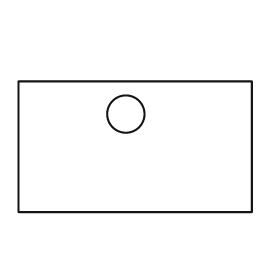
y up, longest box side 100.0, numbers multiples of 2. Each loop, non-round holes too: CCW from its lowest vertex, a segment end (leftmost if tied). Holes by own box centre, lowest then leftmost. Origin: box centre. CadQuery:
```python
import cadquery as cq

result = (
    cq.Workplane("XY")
    .moveTo(-50.0, -28.0)
    .lineTo(50.0, -28.0)
    .lineTo(50.0, 28.0)
    .lineTo(-50.0, 28.0)
    .close()
    .moveTo(-4.0, 14.0)
    .circle(8.0)
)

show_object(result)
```